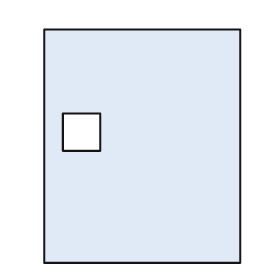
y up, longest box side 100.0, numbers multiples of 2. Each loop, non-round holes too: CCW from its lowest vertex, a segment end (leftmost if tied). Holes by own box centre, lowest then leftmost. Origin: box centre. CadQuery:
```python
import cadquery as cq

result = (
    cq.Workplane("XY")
    .moveTo(-42.0, -50.0)
    .lineTo(42.0, -50.0)
    .lineTo(42.0, 50.0)
    .lineTo(-42.0, 50.0)
    .close()
    .moveTo(-34.0, -2.0)
    .lineTo(-18.0, -2.0)
    .lineTo(-18.0, 14.0)
    .lineTo(-34.0, 14.0)
    .close()
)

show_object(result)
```